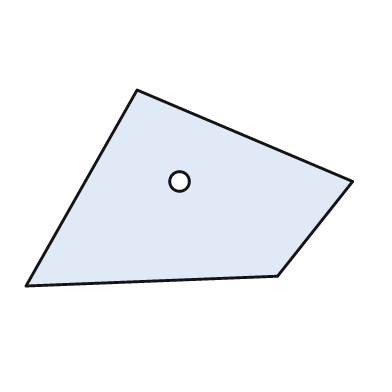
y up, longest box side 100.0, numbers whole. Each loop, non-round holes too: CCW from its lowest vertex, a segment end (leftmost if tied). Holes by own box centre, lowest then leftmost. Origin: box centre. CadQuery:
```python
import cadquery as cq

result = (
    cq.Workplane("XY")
    .moveTo(-50.0, -30.0)
    .lineTo(27.0, -27.0)
    .lineTo(50.0, 2.0)
    .lineTo(-16.0, 30.0)
    .close()
    .moveTo(-3.0, 2.0)
    .circle(3.0)
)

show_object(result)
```